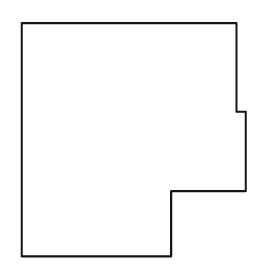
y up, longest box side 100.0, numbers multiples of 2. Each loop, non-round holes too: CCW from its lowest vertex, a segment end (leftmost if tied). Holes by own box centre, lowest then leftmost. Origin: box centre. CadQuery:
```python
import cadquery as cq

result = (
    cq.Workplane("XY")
    .moveTo(-48.0, -50.0)
    .lineTo(16.0, -50.0)
    .lineTo(16.0, -22.0)
    .lineTo(48.0, -22.0)
    .lineTo(48.0, 12.0)
    .lineTo(44.0, 12.0)
    .lineTo(44.0, 50.0)
    .lineTo(-48.0, 50.0)
    .close()
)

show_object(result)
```